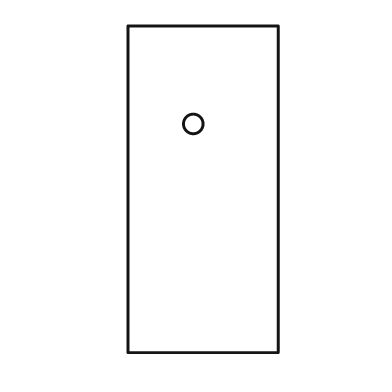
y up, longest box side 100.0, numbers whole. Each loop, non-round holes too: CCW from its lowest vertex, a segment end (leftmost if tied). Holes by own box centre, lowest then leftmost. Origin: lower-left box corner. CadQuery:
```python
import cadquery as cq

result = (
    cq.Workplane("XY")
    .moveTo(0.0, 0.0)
    .lineTo(46.0, 0.0)
    .lineTo(46.0, 100.0)
    .lineTo(0.0, 100.0)
    .close()
    .moveTo(20.0, 70.0)
    .circle(3.0)
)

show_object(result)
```